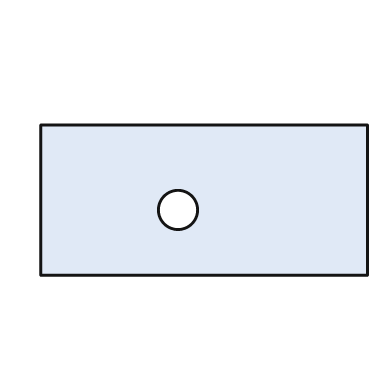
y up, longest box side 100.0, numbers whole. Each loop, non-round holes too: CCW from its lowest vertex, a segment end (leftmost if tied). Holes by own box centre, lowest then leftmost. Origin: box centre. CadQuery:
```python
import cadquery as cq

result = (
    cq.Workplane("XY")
    .moveTo(-50.0, -23.0)
    .lineTo(50.0, -23.0)
    .lineTo(50.0, 23.0)
    .lineTo(-50.0, 23.0)
    .close()
    .moveTo(-8.0, -3.0)
    .circle(6.0)
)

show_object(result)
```